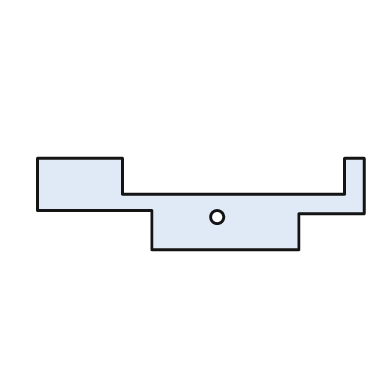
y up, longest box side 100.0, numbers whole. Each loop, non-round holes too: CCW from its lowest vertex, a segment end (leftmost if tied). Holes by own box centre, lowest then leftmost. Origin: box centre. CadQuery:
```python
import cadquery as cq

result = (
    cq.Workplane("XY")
    .moveTo(-15.0, -14.0)
    .lineTo(30.0, -14.0)
    .lineTo(30.0, -3.0)
    .lineTo(50.0, -3.0)
    .lineTo(50.0, 14.0)
    .lineTo(44.0, 14.0)
    .lineTo(44.0, 3.0)
    .lineTo(-24.0, 3.0)
    .lineTo(-24.0, 14.0)
    .lineTo(-50.0, 14.0)
    .lineTo(-50.0, -2.0)
    .lineTo(-15.0, -2.0)
    .close()
    .moveTo(5.0, -4.0)
    .circle(2.0)
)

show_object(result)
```